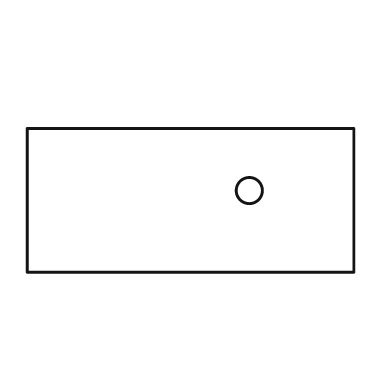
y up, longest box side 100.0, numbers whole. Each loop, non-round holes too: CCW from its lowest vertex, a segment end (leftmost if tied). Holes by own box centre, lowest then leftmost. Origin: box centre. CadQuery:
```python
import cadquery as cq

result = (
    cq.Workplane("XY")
    .moveTo(-50.0, -22.0)
    .lineTo(50.0, -22.0)
    .lineTo(50.0, 22.0)
    .lineTo(-50.0, 22.0)
    .close()
    .moveTo(18.0, 3.0)
    .circle(4.0)
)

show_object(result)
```